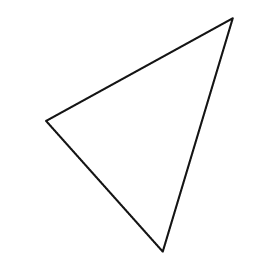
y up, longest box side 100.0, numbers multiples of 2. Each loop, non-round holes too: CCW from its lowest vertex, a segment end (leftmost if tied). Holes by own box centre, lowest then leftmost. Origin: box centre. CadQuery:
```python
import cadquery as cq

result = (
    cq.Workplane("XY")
    .moveTo(10.0, -50.0)
    .lineTo(40.0, 50.0)
    .lineTo(-40.0, 6.0)
    .close()
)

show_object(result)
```